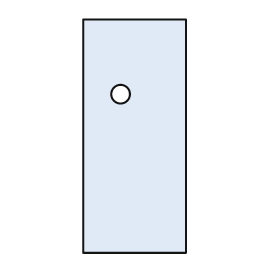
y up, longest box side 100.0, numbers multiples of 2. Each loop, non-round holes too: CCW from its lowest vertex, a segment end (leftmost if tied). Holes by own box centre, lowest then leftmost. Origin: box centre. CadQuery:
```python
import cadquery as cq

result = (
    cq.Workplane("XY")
    .moveTo(-22.0, -50.0)
    .lineTo(22.0, -50.0)
    .lineTo(22.0, 50.0)
    .lineTo(-22.0, 50.0)
    .close()
    .moveTo(-6.0, 18.0)
    .circle(4.0)
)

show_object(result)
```